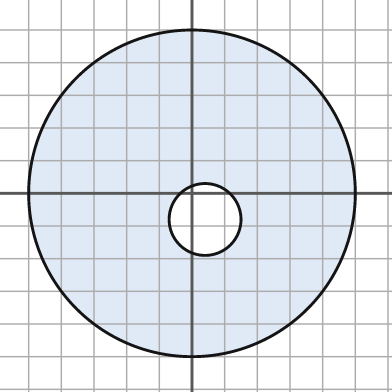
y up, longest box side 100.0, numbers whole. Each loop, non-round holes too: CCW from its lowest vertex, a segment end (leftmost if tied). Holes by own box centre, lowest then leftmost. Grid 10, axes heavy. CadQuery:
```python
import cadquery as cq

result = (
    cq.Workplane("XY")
    .moveTo(0.0, 0.0)
    .circle(50.0)
    .moveTo(4.0, -8.0)
    .circle(11.0)
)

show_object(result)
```